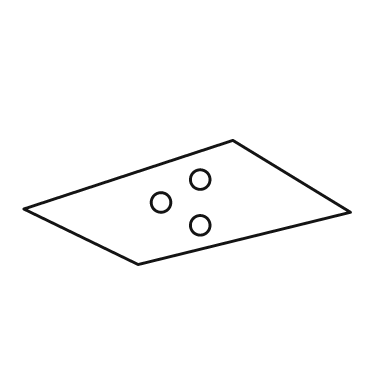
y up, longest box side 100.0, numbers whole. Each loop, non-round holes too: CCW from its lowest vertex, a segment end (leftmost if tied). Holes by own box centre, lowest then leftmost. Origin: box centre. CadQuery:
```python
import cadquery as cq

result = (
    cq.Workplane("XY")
    .moveTo(-15.0, -19.0)
    .lineTo(50.0, -3.0)
    .lineTo(14.0, 19.0)
    .lineTo(-50.0, -2.0)
    .close()
    .moveTo(4.0, -7.0)
    .circle(3.0)
    .moveTo(-8.0, 0.0)
    .circle(3.0)
    .moveTo(4.0, 7.0)
    .circle(3.0)
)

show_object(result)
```